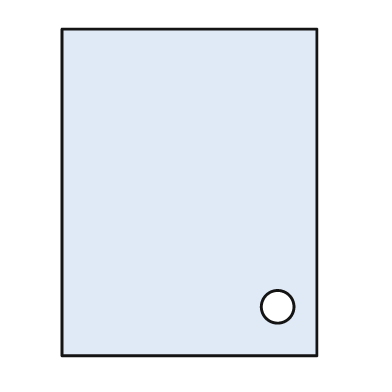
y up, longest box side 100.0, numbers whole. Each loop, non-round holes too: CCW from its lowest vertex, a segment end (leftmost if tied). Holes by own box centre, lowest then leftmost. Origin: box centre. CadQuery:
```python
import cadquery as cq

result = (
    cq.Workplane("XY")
    .moveTo(-39.0, -50.0)
    .lineTo(39.0, -50.0)
    .lineTo(39.0, 50.0)
    .lineTo(-39.0, 50.0)
    .close()
    .moveTo(27.0, -35.0)
    .circle(5.0)
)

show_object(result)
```